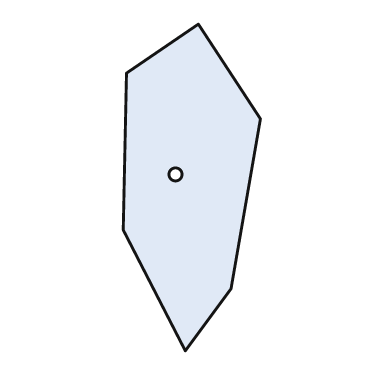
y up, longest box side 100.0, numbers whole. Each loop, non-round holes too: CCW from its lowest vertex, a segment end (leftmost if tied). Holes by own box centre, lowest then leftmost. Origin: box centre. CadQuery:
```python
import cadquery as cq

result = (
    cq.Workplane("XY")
    .moveTo(-2.0, -50.0)
    .lineTo(12.0, -31.0)
    .lineTo(21.0, 21.0)
    .lineTo(2.0, 50.0)
    .lineTo(-20.0, 35.0)
    .lineTo(-21.0, -13.0)
    .close()
    .moveTo(-5.0, 4.0)
    .circle(2.0)
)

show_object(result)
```